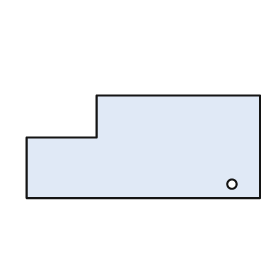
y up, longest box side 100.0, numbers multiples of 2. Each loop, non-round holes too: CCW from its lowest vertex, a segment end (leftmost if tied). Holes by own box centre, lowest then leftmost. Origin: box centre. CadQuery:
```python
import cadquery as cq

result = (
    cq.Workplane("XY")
    .moveTo(-50.0, -22.0)
    .lineTo(50.0, -22.0)
    .lineTo(50.0, 22.0)
    .lineTo(-20.0, 22.0)
    .lineTo(-20.0, 4.0)
    .lineTo(-50.0, 4.0)
    .close()
    .moveTo(38.0, -16.0)
    .circle(2.0)
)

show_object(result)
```